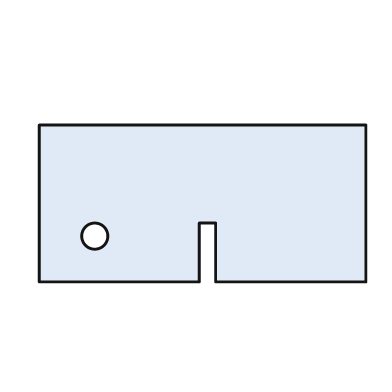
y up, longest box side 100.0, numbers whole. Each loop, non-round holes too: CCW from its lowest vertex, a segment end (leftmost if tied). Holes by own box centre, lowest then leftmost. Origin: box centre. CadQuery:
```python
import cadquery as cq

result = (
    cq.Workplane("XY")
    .moveTo(-50.0, -24.0)
    .lineTo(-1.0, -24.0)
    .lineTo(-1.0, -6.0)
    .lineTo(4.0, -6.0)
    .lineTo(4.0, -24.0)
    .lineTo(50.0, -24.0)
    .lineTo(50.0, 24.0)
    .lineTo(-50.0, 24.0)
    .close()
    .moveTo(-33.0, -10.0)
    .circle(4.0)
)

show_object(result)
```